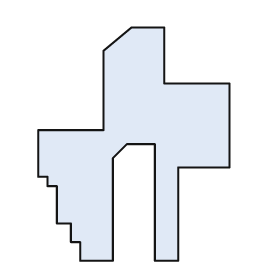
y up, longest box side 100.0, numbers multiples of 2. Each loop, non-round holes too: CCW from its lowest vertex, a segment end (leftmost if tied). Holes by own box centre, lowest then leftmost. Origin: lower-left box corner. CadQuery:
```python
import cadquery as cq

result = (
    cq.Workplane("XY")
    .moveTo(18.0, 0.0)
    .lineTo(32.0, 0.0)
    .lineTo(32.0, 44.0)
    .lineTo(38.0, 50.0)
    .lineTo(50.0, 50.0)
    .lineTo(50.0, 0.0)
    .lineTo(60.0, 0.0)
    .lineTo(60.0, 40.0)
    .lineTo(82.0, 40.0)
    .lineTo(82.0, 76.0)
    .lineTo(54.0, 76.0)
    .lineTo(54.0, 100.0)
    .lineTo(40.0, 100.0)
    .lineTo(28.0, 90.0)
    .lineTo(28.0, 56.0)
    .lineTo(0.0, 56.0)
    .lineTo(0.0, 36.0)
    .lineTo(4.0, 36.0)
    .lineTo(4.0, 32.0)
    .lineTo(8.0, 32.0)
    .lineTo(8.0, 16.0)
    .lineTo(14.0, 16.0)
    .lineTo(14.0, 8.0)
    .lineTo(18.0, 8.0)
    .close()
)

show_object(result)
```